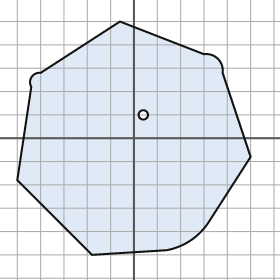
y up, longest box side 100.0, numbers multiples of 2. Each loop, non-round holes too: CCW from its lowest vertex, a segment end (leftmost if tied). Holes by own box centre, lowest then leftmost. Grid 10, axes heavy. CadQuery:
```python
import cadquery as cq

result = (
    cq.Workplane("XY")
    .moveTo(-18.0, -50.0)
    .lineTo(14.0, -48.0)
    .threePointArc((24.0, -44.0), (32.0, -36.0))
    .lineTo(50.0, -8.0)
    .lineTo(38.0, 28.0)
    .threePointArc((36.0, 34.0), (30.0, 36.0))
    .lineTo(-6.0, 50.0)
    .lineTo(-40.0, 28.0)
    .threePointArc((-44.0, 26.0), (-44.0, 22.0))
    .lineTo(-50.0, -18.0)
    .close()
    .moveTo(4.0, 10.0)
    .circle(2.0)
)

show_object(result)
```